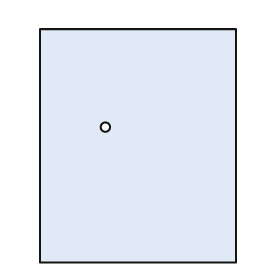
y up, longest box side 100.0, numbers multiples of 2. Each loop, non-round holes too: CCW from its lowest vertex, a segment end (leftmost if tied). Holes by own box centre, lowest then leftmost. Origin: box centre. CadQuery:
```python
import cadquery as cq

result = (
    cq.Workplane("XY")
    .moveTo(-42.0, -50.0)
    .lineTo(42.0, -50.0)
    .lineTo(42.0, 50.0)
    .lineTo(-42.0, 50.0)
    .close()
    .moveTo(-14.0, 8.0)
    .circle(2.0)
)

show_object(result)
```